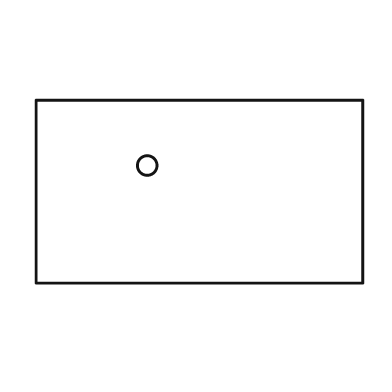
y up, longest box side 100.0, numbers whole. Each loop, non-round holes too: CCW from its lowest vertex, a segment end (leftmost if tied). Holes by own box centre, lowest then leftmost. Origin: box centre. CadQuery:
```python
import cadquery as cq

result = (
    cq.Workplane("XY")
    .moveTo(-50.0, -28.0)
    .lineTo(50.0, -28.0)
    .lineTo(50.0, 28.0)
    .lineTo(-50.0, 28.0)
    .close()
    .moveTo(-16.0, 8.0)
    .circle(3.0)
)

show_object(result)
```